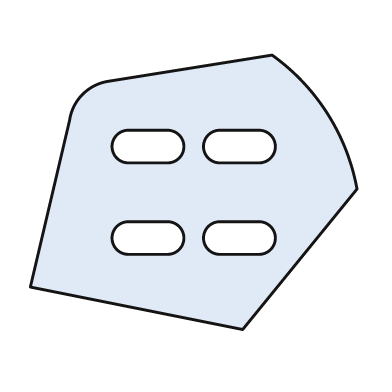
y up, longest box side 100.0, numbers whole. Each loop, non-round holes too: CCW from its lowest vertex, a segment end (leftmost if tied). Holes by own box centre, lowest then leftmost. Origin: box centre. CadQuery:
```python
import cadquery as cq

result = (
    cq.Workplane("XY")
    .moveTo(15.0, -42.0)
    .lineTo(50.0, 1.0)
    .threePointArc((41.0, 24.0), (24.0, 42.0))
    .lineTo(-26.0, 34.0)
    .threePointArc((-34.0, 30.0), (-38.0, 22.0))
    .lineTo(-50.0, -29.0)
    .close()
    .moveTo(-20.0, -19.0)
    .lineTo(-8.0, -19.0)
    .threePointArc((-3.0, -14.0), (-8.0, -9.0))
    .lineTo(-20.0, -9.0)
    .threePointArc((-25.0, -14.0), (-20.0, -19.0))
    .close()
    .moveTo(8.0, -19.0)
    .lineTo(20.0, -19.0)
    .threePointArc((25.0, -14.0), (20.0, -9.0))
    .lineTo(8.0, -9.0)
    .threePointArc((3.0, -14.0), (8.0, -19.0))
    .close()
    .moveTo(-20.0, 9.0)
    .lineTo(-8.0, 9.0)
    .threePointArc((-3.0, 14.0), (-8.0, 19.0))
    .lineTo(-20.0, 19.0)
    .threePointArc((-25.0, 14.0), (-20.0, 9.0))
    .close()
    .moveTo(8.0, 9.0)
    .lineTo(20.0, 9.0)
    .threePointArc((25.0, 14.0), (20.0, 19.0))
    .lineTo(8.0, 19.0)
    .threePointArc((3.0, 14.0), (8.0, 9.0))
    .close()
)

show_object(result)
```